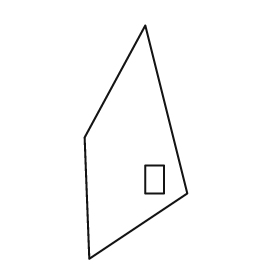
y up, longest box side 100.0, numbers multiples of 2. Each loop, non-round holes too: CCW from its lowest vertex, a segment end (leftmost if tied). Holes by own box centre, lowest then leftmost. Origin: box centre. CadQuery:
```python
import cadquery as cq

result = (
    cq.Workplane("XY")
    .moveTo(-20.0, -50.0)
    .lineTo(22.0, -22.0)
    .lineTo(4.0, 50.0)
    .lineTo(-22.0, 2.0)
    .close()
    .moveTo(4.0, -22.0)
    .lineTo(12.0, -22.0)
    .lineTo(12.0, -10.0)
    .lineTo(4.0, -10.0)
    .close()
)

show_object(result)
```